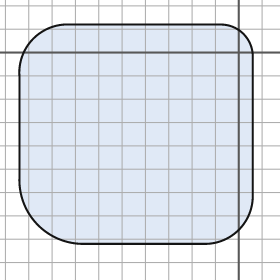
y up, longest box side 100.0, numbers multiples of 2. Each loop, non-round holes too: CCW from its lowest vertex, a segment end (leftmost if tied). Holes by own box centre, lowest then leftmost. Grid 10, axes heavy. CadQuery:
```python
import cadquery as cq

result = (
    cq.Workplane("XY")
    .moveTo(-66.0, -82.0)
    .lineTo(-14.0, -82.0)
    .threePointArc((0.0, -76.0), (6.0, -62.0))
    .lineTo(6.0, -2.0)
    .threePointArc((2.0, 8.0), (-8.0, 12.0))
    .lineTo(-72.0, 12.0)
    .threePointArc((-88.0, 6.0), (-94.0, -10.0))
    .lineTo(-94.0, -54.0)
    .threePointArc((-86.0, -74.0), (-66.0, -82.0))
    .close()
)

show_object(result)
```